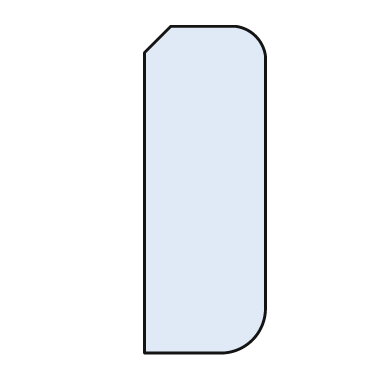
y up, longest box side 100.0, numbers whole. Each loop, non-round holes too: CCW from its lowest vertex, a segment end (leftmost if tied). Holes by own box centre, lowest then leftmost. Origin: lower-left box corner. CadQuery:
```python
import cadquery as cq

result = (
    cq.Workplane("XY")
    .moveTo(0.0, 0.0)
    .lineTo(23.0, 0.0)
    .threePointArc((33.0, 4.0), (37.0, 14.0))
    .lineTo(37.0, 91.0)
    .threePointArc((34.0, 97.0), (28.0, 100.0))
    .lineTo(8.0, 100.0)
    .lineTo(0.0, 92.0)
    .close()
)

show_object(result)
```